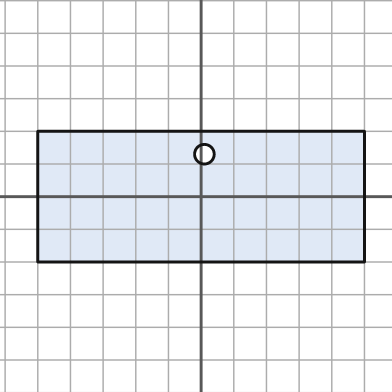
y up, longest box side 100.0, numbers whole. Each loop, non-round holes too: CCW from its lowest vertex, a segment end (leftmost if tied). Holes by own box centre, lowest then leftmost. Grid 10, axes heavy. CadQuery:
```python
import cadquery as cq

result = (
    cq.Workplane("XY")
    .moveTo(-50.0, -20.0)
    .lineTo(50.0, -20.0)
    .lineTo(50.0, 20.0)
    .lineTo(-50.0, 20.0)
    .close()
    .moveTo(1.0, 13.0)
    .circle(3.0)
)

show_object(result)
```